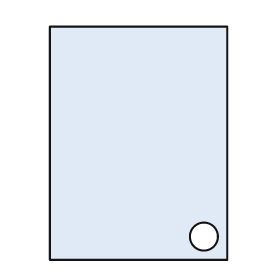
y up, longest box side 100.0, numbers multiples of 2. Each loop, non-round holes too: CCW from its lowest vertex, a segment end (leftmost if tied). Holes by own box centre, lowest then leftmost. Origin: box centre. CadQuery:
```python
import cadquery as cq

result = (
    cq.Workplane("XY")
    .moveTo(-38.0, -50.0)
    .lineTo(38.0, -50.0)
    .lineTo(38.0, 50.0)
    .lineTo(-38.0, 50.0)
    .close()
    .moveTo(28.0, -40.0)
    .circle(6.0)
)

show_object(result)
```